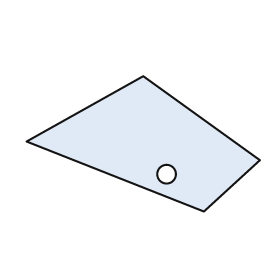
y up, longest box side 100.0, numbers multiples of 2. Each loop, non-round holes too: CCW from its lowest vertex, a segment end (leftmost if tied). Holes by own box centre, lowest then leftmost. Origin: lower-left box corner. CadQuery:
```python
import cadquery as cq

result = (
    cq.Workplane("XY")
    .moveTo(76.0, 0.0)
    .lineTo(100.0, 22.0)
    .lineTo(50.0, 58.0)
    .lineTo(0.0, 30.0)
    .close()
    .moveTo(60.0, 16.0)
    .circle(4.0)
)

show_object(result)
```